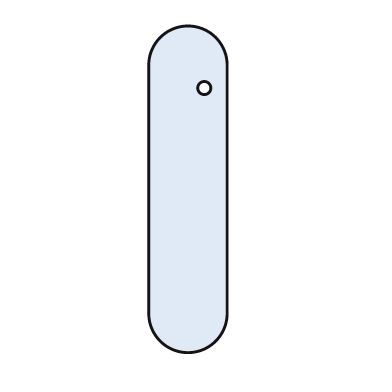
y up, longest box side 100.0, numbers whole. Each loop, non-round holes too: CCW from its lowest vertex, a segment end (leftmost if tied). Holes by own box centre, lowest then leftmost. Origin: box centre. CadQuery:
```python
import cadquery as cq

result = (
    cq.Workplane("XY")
    .moveTo(-12.0, -38.0)
    .threePointArc((0.0, -50.0), (12.0, -38.0))
    .lineTo(12.0, 38.0)
    .threePointArc((0.0, 50.0), (-12.0, 38.0))
    .close()
    .moveTo(5.0, 31.0)
    .circle(2.0)
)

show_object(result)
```